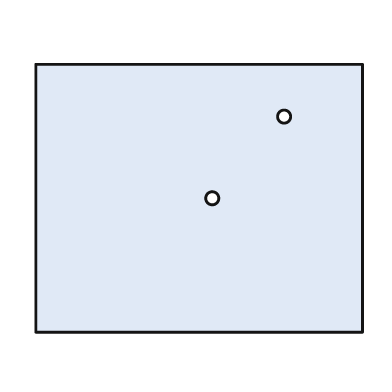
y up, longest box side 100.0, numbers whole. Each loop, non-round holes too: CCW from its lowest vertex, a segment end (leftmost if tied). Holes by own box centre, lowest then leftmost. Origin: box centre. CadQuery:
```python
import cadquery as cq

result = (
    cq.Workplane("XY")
    .moveTo(-50.0, -41.0)
    .lineTo(50.0, -41.0)
    .lineTo(50.0, 41.0)
    .lineTo(-50.0, 41.0)
    .close()
    .moveTo(4.0, 0.0)
    .circle(2.0)
    .moveTo(26.0, 25.0)
    .circle(2.0)
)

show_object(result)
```